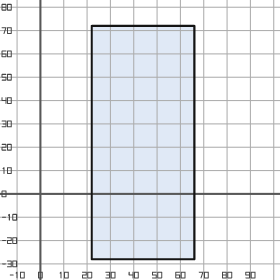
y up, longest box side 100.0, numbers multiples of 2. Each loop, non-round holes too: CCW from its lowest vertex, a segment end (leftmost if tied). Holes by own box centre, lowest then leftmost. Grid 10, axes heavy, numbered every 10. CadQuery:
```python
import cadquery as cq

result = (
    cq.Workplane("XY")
    .moveTo(22.0, -28.0)
    .lineTo(66.0, -28.0)
    .lineTo(66.0, 72.0)
    .lineTo(22.0, 72.0)
    .close()
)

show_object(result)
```